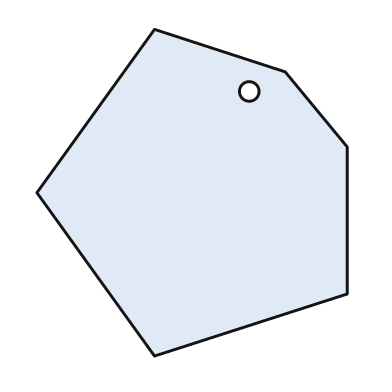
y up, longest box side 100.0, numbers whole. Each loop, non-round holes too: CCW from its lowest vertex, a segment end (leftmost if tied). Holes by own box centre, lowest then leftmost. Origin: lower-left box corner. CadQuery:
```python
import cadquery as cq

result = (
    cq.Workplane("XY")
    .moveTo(36.0, 0.0)
    .lineTo(95.0, 19.0)
    .lineTo(95.0, 64.0)
    .lineTo(76.0, 87.0)
    .lineTo(36.0, 100.0)
    .lineTo(0.0, 50.0)
    .close()
    .moveTo(65.0, 81.0)
    .circle(3.0)
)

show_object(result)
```